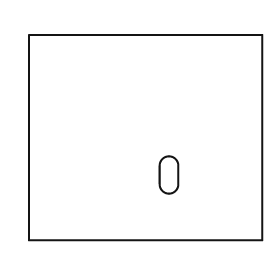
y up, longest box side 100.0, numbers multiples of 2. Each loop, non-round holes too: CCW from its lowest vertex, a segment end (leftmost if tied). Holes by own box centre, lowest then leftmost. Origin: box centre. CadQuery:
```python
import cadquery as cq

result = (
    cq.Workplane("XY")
    .moveTo(-50.0, -44.0)
    .lineTo(50.0, -44.0)
    .lineTo(50.0, 44.0)
    .lineTo(-50.0, 44.0)
    .close()
    .moveTo(6.0, -20.0)
    .threePointArc((10.0, -24.0), (14.0, -20.0))
    .lineTo(14.0, -12.0)
    .threePointArc((10.0, -8.0), (6.0, -12.0))
    .close()
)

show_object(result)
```